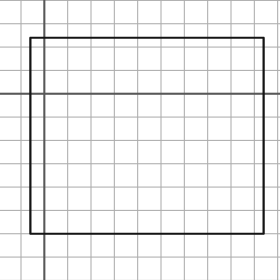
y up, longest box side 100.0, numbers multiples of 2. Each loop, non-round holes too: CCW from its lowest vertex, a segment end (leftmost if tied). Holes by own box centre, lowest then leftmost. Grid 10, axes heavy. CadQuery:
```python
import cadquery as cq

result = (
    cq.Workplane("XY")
    .moveTo(-6.0, -60.0)
    .lineTo(94.0, -60.0)
    .lineTo(94.0, 24.0)
    .lineTo(-6.0, 24.0)
    .close()
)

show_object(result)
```